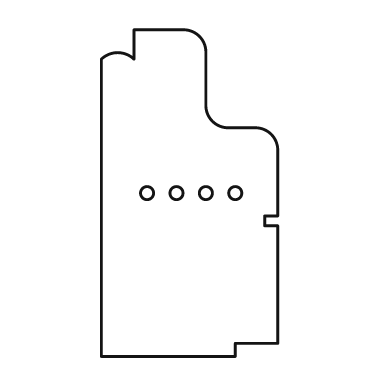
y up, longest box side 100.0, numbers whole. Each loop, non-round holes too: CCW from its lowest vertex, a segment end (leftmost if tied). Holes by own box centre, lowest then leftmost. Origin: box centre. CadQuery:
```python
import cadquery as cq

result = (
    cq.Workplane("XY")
    .moveTo(-27.0, -50.0)
    .lineTo(14.0, -50.0)
    .lineTo(14.0, -46.0)
    .lineTo(27.0, -46.0)
    .lineTo(27.0, -10.0)
    .lineTo(23.0, -10.0)
    .lineTo(23.0, -7.0)
    .lineTo(27.0, -7.0)
    .lineTo(27.0, 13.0)
    .threePointArc((25.0, 18.0), (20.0, 20.0))
    .lineTo(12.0, 20.0)
    .threePointArc((7.0, 22.0), (5.0, 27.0))
    .lineTo(5.0, 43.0)
    .threePointArc((3.0, 48.0), (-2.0, 50.0))
    .lineTo(-17.0, 50.0)
    .lineTo(-17.0, 41.0)
    .threePointArc((-22.0, 43.0), (-27.0, 41.0))
    .close()
    .moveTo(-13.0, 0.0)
    .circle(2.0)
    .moveTo(-4.0, 0.0)
    .circle(2.0)
    .moveTo(5.0, 0.0)
    .circle(2.0)
    .moveTo(14.0, 0.0)
    .circle(2.0)
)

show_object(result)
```